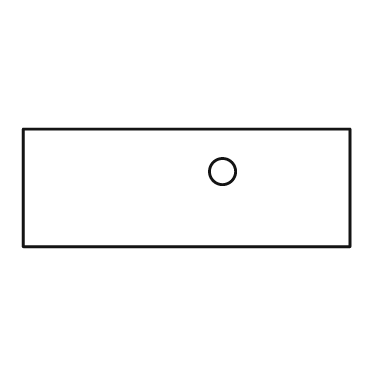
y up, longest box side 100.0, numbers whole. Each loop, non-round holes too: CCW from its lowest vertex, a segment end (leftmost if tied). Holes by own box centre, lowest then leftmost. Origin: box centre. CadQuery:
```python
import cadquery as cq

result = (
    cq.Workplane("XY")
    .moveTo(-50.0, -18.0)
    .lineTo(50.0, -18.0)
    .lineTo(50.0, 18.0)
    .lineTo(-50.0, 18.0)
    .close()
    .moveTo(11.0, 5.0)
    .circle(4.0)
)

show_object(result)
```